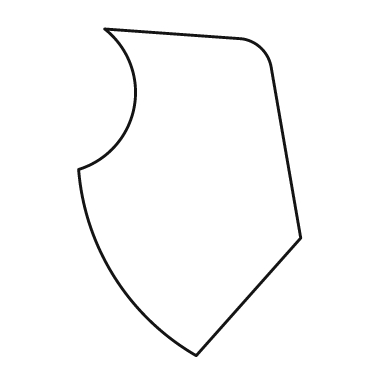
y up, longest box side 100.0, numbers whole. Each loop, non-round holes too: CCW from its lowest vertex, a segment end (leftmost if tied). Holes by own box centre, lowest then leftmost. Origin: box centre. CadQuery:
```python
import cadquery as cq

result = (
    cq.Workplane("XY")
    .moveTo(2.0, -50.0)
    .lineTo(34.0, -14.0)
    .lineTo(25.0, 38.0)
    .threePointArc((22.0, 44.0), (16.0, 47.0))
    .lineTo(-26.0, 50.0)
    .threePointArc((-17.0, 26.0), (-34.0, 7.0))
    .threePointArc((-23.0, -26.0), (2.0, -50.0))
    .close()
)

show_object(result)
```